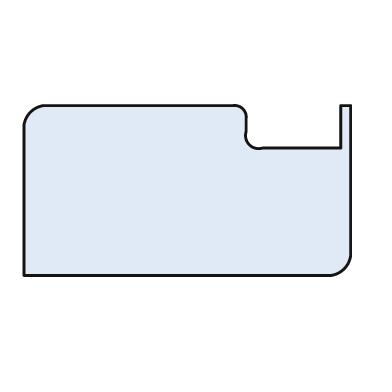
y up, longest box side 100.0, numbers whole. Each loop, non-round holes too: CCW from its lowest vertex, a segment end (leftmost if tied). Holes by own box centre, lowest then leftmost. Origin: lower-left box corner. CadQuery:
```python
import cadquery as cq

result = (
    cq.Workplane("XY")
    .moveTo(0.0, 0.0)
    .lineTo(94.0, 0.0)
    .threePointArc((98.0, 2.0), (100.0, 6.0))
    .lineTo(100.0, 52.0)
    .lineTo(97.0, 52.0)
    .lineTo(97.0, 39.0)
    .lineTo(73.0, 39.0)
    .threePointArc((69.0, 40.0), (68.0, 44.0))
    .lineTo(68.0, 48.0)
    .threePointArc((67.0, 51.0), (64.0, 52.0))
    .lineTo(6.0, 52.0)
    .threePointArc((2.0, 50.0), (0.0, 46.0))
    .close()
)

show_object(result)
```